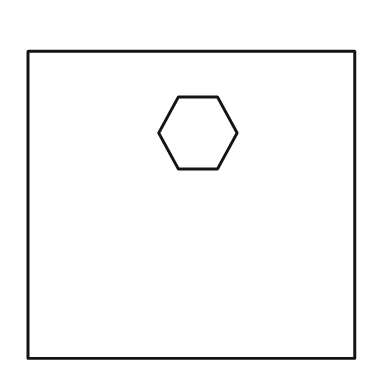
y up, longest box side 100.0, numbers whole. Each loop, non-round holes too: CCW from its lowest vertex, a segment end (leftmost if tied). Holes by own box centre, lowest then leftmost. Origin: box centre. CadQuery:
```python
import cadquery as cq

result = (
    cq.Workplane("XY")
    .moveTo(-50.0, -47.0)
    .lineTo(50.0, -47.0)
    .lineTo(50.0, 47.0)
    .lineTo(-50.0, 47.0)
    .close()
    .moveTo(-4.0, 11.0)
    .lineTo(8.0, 11.0)
    .lineTo(14.0, 22.0)
    .lineTo(8.0, 33.0)
    .lineTo(-4.0, 33.0)
    .lineTo(-10.0, 22.0)
    .close()
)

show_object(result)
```